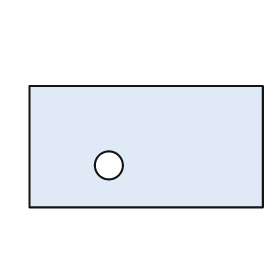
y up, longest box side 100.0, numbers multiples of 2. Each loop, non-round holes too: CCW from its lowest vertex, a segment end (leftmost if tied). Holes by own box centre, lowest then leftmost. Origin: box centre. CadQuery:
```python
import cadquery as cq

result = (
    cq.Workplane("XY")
    .moveTo(-50.0, -26.0)
    .lineTo(50.0, -26.0)
    .lineTo(50.0, 26.0)
    .lineTo(-50.0, 26.0)
    .close()
    .moveTo(-16.0, -8.0)
    .circle(6.0)
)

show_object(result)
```